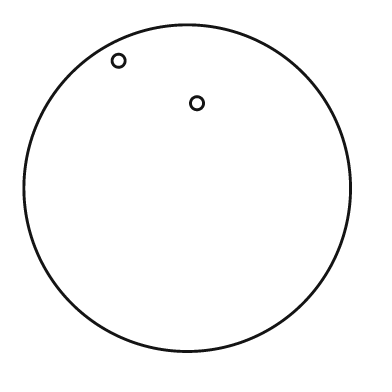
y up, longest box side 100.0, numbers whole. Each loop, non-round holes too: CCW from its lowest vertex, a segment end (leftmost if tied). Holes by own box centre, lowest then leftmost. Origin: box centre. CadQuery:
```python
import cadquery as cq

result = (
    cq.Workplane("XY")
    .moveTo(0.0, 0.0)
    .circle(50.0)
    .moveTo(3.0, 26.0)
    .circle(2.0)
    .moveTo(-21.0, 39.0)
    .circle(2.0)
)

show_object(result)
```